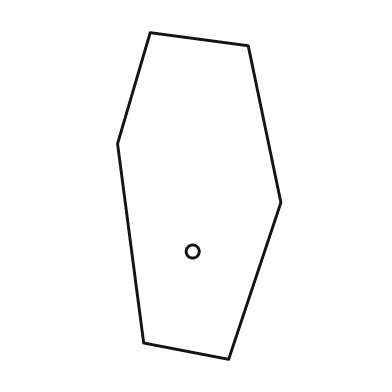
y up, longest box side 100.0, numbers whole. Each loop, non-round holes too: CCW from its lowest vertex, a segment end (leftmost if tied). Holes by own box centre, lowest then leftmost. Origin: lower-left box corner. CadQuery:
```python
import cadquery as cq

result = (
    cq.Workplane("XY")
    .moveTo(34.0, 0.0)
    .lineTo(50.0, 48.0)
    .lineTo(40.0, 96.0)
    .lineTo(10.0, 100.0)
    .lineTo(0.0, 66.0)
    .lineTo(8.0, 5.0)
    .close()
    .moveTo(23.0, 33.0)
    .circle(2.0)
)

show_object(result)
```